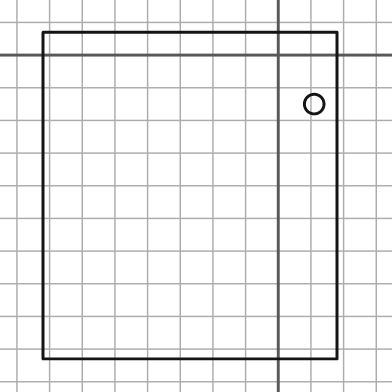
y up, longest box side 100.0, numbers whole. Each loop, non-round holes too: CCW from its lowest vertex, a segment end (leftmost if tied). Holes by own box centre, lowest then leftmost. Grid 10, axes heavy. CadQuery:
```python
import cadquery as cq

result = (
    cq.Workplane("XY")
    .moveTo(-72.0, -93.0)
    .lineTo(18.0, -93.0)
    .lineTo(18.0, 7.0)
    .lineTo(-72.0, 7.0)
    .close()
    .moveTo(11.0, -15.0)
    .circle(3.0)
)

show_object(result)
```